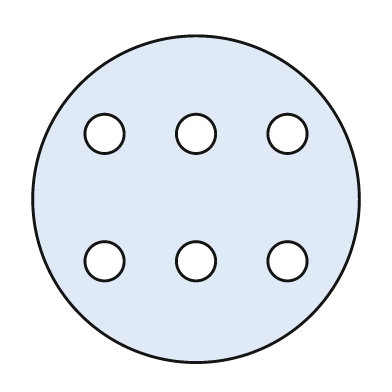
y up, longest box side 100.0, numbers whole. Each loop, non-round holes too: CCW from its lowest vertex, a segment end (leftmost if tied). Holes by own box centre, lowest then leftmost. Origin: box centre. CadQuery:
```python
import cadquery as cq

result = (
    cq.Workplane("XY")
    .moveTo(0.0, 0.0)
    .circle(50.0)
    .moveTo(-28.0, -19.0)
    .circle(6.0)
    .moveTo(0.0, -19.0)
    .circle(6.0)
    .moveTo(28.0, -19.0)
    .circle(6.0)
    .moveTo(-28.0, 20.0)
    .circle(6.0)
    .moveTo(0.0, 20.0)
    .circle(6.0)
    .moveTo(28.0, 20.0)
    .circle(6.0)
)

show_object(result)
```